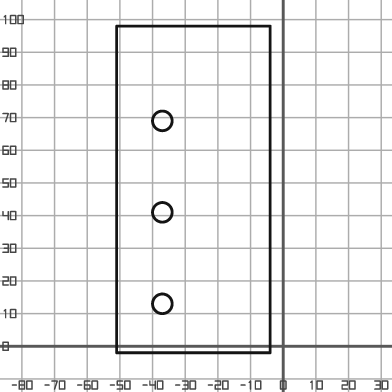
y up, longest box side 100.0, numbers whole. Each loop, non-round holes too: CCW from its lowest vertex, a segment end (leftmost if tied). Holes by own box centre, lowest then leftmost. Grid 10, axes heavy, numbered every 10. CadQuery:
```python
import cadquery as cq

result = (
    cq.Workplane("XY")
    .moveTo(-51.0, -2.0)
    .lineTo(-4.0, -2.0)
    .lineTo(-4.0, 98.0)
    .lineTo(-51.0, 98.0)
    .close()
    .moveTo(-37.0, 13.0)
    .circle(3.0)
    .moveTo(-37.0, 41.0)
    .circle(3.0)
    .moveTo(-37.0, 69.0)
    .circle(3.0)
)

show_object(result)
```